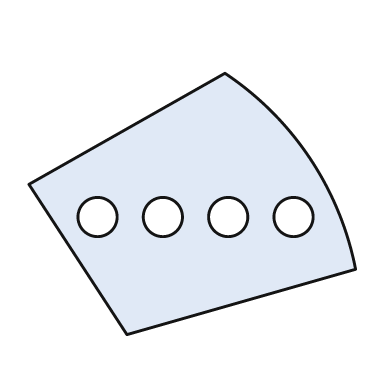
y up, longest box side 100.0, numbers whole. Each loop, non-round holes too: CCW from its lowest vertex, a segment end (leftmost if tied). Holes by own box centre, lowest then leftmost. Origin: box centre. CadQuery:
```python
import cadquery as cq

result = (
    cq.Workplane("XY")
    .moveTo(-20.0, -40.0)
    .lineTo(50.0, -20.0)
    .threePointArc((36.0, 14.0), (10.0, 40.0))
    .lineTo(-50.0, 6.0)
    .close()
    .moveTo(-29.0, -4.0)
    .circle(6.0)
    .moveTo(-9.0, -4.0)
    .circle(6.0)
    .moveTo(11.0, -4.0)
    .circle(6.0)
    .moveTo(31.0, -4.0)
    .circle(6.0)
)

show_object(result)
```